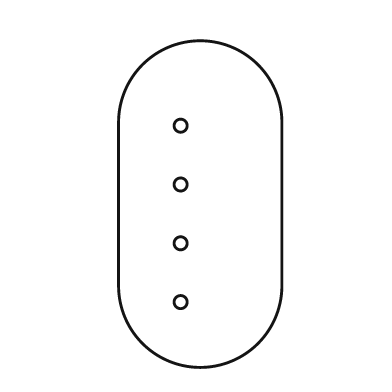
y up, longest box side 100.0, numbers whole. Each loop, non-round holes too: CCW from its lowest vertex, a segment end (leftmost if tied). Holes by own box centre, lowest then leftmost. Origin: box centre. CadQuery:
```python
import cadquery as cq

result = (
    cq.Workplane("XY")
    .moveTo(-25.0, -25.0)
    .threePointArc((0.0, -50.0), (25.0, -25.0))
    .lineTo(25.0, 25.0)
    .threePointArc((0.0, 50.0), (-25.0, 25.0))
    .close()
    .moveTo(-6.0, -30.0)
    .circle(2.0)
    .moveTo(-6.0, -12.0)
    .circle(2.0)
    .moveTo(-6.0, 6.0)
    .circle(2.0)
    .moveTo(-6.0, 24.0)
    .circle(2.0)
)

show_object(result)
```